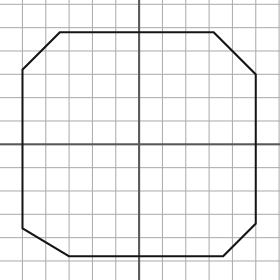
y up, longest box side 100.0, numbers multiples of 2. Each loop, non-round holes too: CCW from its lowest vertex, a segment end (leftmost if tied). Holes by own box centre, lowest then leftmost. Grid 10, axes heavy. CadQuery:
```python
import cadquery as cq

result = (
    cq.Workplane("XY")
    .moveTo(-30.0, -48.0)
    .lineTo(36.0, -48.0)
    .lineTo(50.0, -34.0)
    .lineTo(50.0, 30.0)
    .lineTo(32.0, 48.0)
    .lineTo(-34.0, 48.0)
    .lineTo(-50.0, 32.0)
    .lineTo(-50.0, -36.0)
    .close()
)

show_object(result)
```